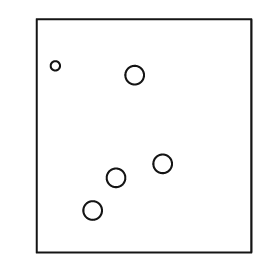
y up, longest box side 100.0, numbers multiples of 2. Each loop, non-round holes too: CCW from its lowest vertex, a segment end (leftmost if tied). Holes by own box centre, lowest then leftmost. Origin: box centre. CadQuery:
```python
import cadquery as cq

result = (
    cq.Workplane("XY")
    .moveTo(-46.0, -50.0)
    .lineTo(46.0, -50.0)
    .lineTo(46.0, 50.0)
    .lineTo(-46.0, 50.0)
    .close()
    .moveTo(-22.0, -32.0)
    .circle(4.0)
    .moveTo(-12.0, -18.0)
    .circle(4.0)
    .moveTo(8.0, -12.0)
    .circle(4.0)
    .moveTo(-4.0, 26.0)
    .circle(4.0)
    .moveTo(-38.0, 30.0)
    .circle(2.0)
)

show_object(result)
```